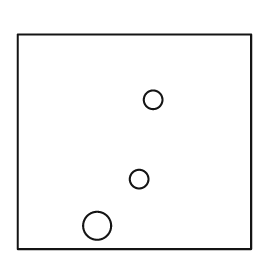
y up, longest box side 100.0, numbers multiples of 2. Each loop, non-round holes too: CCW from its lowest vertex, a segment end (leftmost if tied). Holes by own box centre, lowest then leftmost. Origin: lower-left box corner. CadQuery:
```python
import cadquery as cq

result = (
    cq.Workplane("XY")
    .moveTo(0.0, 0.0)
    .lineTo(100.0, 0.0)
    .lineTo(100.0, 92.0)
    .lineTo(0.0, 92.0)
    .close()
    .moveTo(34.0, 10.0)
    .circle(6.0)
    .moveTo(52.0, 30.0)
    .circle(4.0)
    .moveTo(58.0, 64.0)
    .circle(4.0)
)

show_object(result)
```